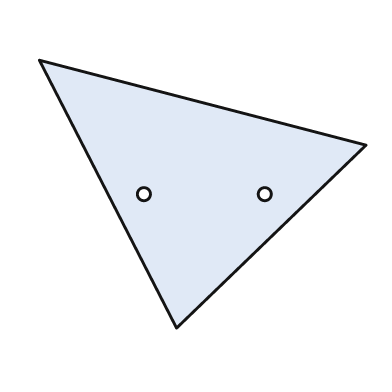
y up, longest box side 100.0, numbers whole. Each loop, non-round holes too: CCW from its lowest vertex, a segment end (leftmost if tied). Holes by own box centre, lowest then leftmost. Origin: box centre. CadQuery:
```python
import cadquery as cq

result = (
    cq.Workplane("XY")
    .moveTo(-8.0, -41.0)
    .lineTo(50.0, 15.0)
    .lineTo(-50.0, 41.0)
    .close()
    .moveTo(-18.0, 0.0)
    .circle(2.0)
    .moveTo(19.0, 0.0)
    .circle(2.0)
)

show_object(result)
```